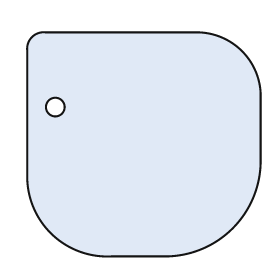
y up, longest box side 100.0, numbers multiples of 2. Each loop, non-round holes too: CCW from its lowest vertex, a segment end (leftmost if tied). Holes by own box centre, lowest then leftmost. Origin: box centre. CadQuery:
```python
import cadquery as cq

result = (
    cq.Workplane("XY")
    .moveTo(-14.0, -48.0)
    .lineTo(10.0, -48.0)
    .threePointArc((38.0, -36.0), (50.0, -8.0))
    .lineTo(50.0, 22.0)
    .threePointArc((42.0, 40.0), (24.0, 48.0))
    .lineTo(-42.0, 48.0)
    .threePointArc((-48.0, 46.0), (-50.0, 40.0))
    .lineTo(-50.0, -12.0)
    .threePointArc((-40.0, -38.0), (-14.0, -48.0))
    .close()
    .moveTo(-38.0, 16.0)
    .circle(4.0)
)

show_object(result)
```